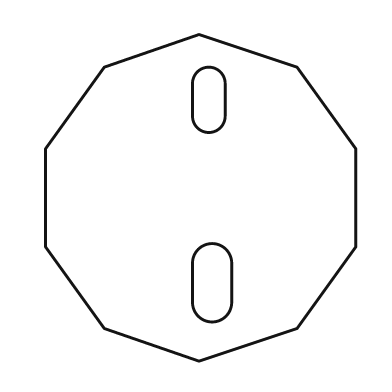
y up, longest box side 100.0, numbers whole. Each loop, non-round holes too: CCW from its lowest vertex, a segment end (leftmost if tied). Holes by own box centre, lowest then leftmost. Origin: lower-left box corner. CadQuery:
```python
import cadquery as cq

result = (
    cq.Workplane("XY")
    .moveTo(47.0, 0.0)
    .lineTo(77.0, 10.0)
    .lineTo(95.0, 35.0)
    .lineTo(95.0, 65.0)
    .lineTo(77.0, 90.0)
    .lineTo(47.0, 100.0)
    .lineTo(18.0, 90.0)
    .lineTo(0.0, 65.0)
    .lineTo(0.0, 35.0)
    .lineTo(18.0, 10.0)
    .close()
    .moveTo(45.0, 18.0)
    .threePointArc((51.0, 12.0), (57.0, 18.0))
    .lineTo(57.0, 30.0)
    .threePointArc((51.0, 36.0), (45.0, 30.0))
    .close()
    .moveTo(45.0, 75.0)
    .threePointArc((50.0, 70.0), (55.0, 75.0))
    .lineTo(55.0, 85.0)
    .threePointArc((50.0, 90.0), (45.0, 85.0))
    .close()
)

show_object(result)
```